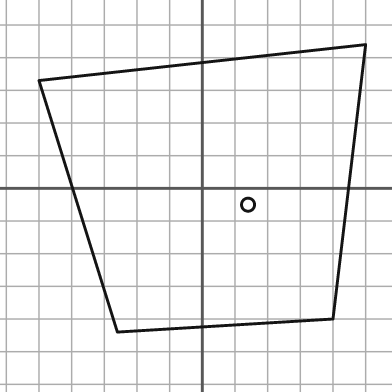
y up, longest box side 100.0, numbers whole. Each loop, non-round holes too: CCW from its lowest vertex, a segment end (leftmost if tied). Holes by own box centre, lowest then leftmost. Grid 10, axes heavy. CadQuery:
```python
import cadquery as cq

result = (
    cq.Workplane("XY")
    .moveTo(-26.0, -44.0)
    .lineTo(40.0, -40.0)
    .lineTo(50.0, 44.0)
    .lineTo(-50.0, 33.0)
    .close()
    .moveTo(14.0, -5.0)
    .circle(2.0)
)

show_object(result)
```